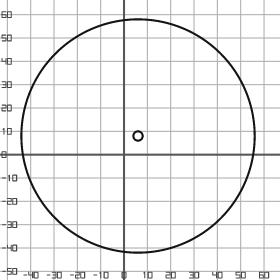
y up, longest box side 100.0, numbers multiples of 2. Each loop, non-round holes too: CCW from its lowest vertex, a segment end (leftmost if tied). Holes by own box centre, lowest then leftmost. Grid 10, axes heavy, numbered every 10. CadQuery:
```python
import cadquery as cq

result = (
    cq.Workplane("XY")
    .moveTo(6.0, 8.0)
    .circle(50.0)
    .moveTo(6.0, 8.0)
    .circle(2.0)
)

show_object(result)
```